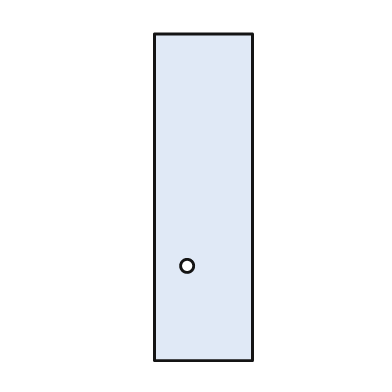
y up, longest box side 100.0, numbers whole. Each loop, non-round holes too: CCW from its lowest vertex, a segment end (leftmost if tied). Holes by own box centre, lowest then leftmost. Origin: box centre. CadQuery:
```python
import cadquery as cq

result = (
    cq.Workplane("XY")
    .moveTo(-15.0, -50.0)
    .lineTo(15.0, -50.0)
    .lineTo(15.0, 50.0)
    .lineTo(-15.0, 50.0)
    .close()
    .moveTo(-5.0, -21.0)
    .circle(2.0)
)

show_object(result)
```